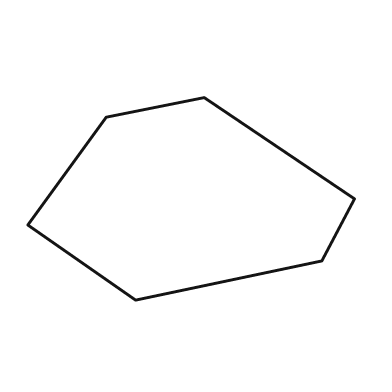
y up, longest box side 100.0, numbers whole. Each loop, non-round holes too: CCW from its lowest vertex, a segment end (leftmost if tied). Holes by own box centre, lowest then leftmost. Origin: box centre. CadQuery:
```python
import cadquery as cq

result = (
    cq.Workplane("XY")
    .moveTo(-17.0, -31.0)
    .lineTo(40.0, -19.0)
    .lineTo(50.0, 0.0)
    .lineTo(4.0, 31.0)
    .lineTo(-26.0, 25.0)
    .lineTo(-50.0, -8.0)
    .close()
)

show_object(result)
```